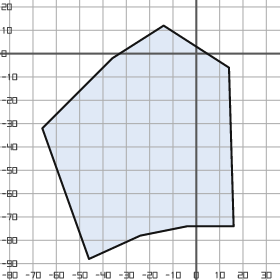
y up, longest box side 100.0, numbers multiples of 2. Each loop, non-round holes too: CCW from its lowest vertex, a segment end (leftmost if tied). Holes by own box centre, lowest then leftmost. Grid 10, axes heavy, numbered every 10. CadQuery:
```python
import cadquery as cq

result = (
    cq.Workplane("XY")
    .moveTo(-46.0, -88.0)
    .lineTo(-24.0, -78.0)
    .lineTo(-4.0, -74.0)
    .lineTo(16.0, -74.0)
    .lineTo(14.0, -6.0)
    .lineTo(-14.0, 12.0)
    .lineTo(-36.0, -2.0)
    .lineTo(-66.0, -32.0)
    .close()
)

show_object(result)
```